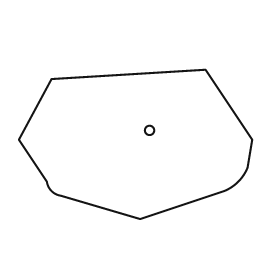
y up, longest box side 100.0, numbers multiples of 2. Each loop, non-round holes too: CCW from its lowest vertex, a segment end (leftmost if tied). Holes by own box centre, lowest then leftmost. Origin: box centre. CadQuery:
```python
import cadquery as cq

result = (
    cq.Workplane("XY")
    .moveTo(2.0, -32.0)
    .lineTo(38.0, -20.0)
    .threePointArc((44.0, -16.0), (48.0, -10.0))
    .lineTo(50.0, 2.0)
    .lineTo(30.0, 32.0)
    .lineTo(-36.0, 28.0)
    .lineTo(-50.0, 2.0)
    .lineTo(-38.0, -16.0)
    .threePointArc((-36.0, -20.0), (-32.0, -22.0))
    .close()
    .moveTo(6.0, 6.0)
    .circle(2.0)
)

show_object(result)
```